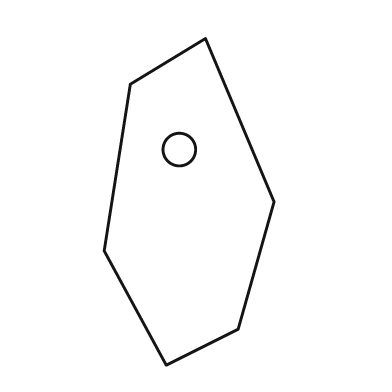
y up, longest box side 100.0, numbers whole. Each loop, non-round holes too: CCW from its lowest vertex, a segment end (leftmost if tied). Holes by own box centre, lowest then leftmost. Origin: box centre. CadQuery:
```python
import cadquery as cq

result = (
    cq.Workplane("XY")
    .moveTo(-7.0, -50.0)
    .lineTo(15.0, -39.0)
    .lineTo(26.0, 0.0)
    .lineTo(5.0, 50.0)
    .lineTo(-18.0, 36.0)
    .lineTo(-26.0, -15.0)
    .close()
    .moveTo(-3.0, 16.0)
    .circle(5.0)
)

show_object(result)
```